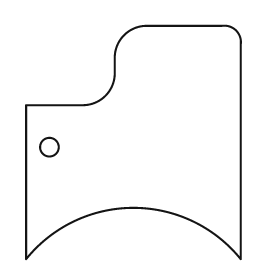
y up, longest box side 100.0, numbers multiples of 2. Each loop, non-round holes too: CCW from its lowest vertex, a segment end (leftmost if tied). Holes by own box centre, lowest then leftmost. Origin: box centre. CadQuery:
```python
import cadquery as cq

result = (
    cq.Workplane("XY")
    .moveTo(-46.0, -50.0)
    .threePointArc((0.0, -28.0), (46.0, -50.0))
    .lineTo(46.0, 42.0)
    .threePointArc((44.0, 48.0), (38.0, 50.0))
    .lineTo(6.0, 50.0)
    .threePointArc((-4.0, 46.0), (-8.0, 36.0))
    .lineTo(-8.0, 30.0)
    .threePointArc((-12.0, 20.0), (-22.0, 16.0))
    .lineTo(-46.0, 16.0)
    .close()
    .moveTo(-36.0, -2.0)
    .circle(4.0)
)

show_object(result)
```